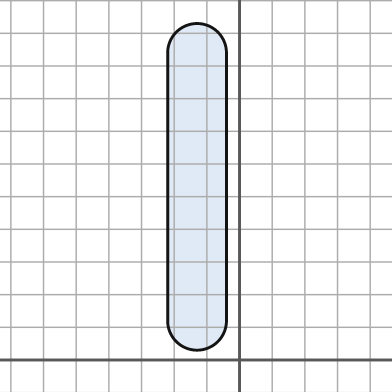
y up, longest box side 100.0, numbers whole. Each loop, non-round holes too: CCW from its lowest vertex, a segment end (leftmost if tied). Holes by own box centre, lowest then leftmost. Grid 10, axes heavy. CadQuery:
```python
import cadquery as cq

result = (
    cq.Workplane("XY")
    .moveTo(-22.0, 12.0)
    .threePointArc((-13.0, 3.0), (-4.0, 12.0))
    .lineTo(-4.0, 94.0)
    .threePointArc((-13.0, 103.0), (-22.0, 94.0))
    .close()
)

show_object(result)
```